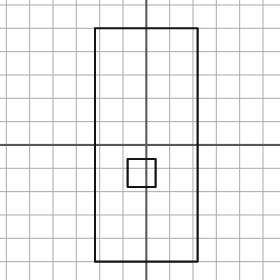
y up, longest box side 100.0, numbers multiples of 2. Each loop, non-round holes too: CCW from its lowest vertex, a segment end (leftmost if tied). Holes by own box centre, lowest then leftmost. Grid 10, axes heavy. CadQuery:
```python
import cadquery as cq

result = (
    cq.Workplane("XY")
    .moveTo(-22.0, -50.0)
    .lineTo(22.0, -50.0)
    .lineTo(22.0, 50.0)
    .lineTo(-22.0, 50.0)
    .close()
    .moveTo(-8.0, -18.0)
    .lineTo(4.0, -18.0)
    .lineTo(4.0, -6.0)
    .lineTo(-8.0, -6.0)
    .close()
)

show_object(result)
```